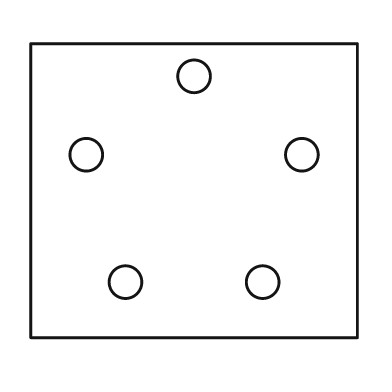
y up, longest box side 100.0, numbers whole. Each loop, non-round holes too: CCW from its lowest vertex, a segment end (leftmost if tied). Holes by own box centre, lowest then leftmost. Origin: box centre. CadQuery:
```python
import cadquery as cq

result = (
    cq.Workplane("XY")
    .moveTo(-50.0, -45.0)
    .lineTo(50.0, -45.0)
    .lineTo(50.0, 45.0)
    .lineTo(-50.0, 45.0)
    .close()
    .moveTo(-21.0, -28.0)
    .circle(5.0)
    .moveTo(21.0, -28.0)
    .circle(5.0)
    .moveTo(-33.0, 11.0)
    .circle(5.0)
    .moveTo(33.0, 11.0)
    .circle(5.0)
    .moveTo(0.0, 35.0)
    .circle(5.0)
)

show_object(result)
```